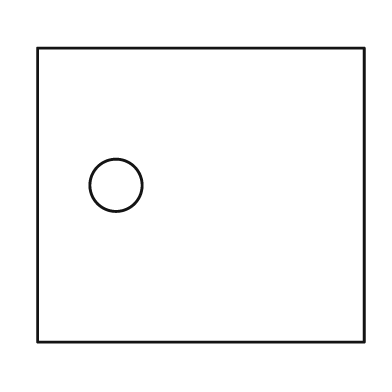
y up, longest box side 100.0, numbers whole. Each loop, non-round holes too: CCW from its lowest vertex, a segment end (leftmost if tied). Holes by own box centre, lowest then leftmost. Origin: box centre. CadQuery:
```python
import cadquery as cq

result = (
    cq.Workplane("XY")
    .moveTo(-50.0, -45.0)
    .lineTo(50.0, -45.0)
    .lineTo(50.0, 45.0)
    .lineTo(-50.0, 45.0)
    .close()
    .moveTo(-26.0, 3.0)
    .circle(8.0)
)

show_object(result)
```